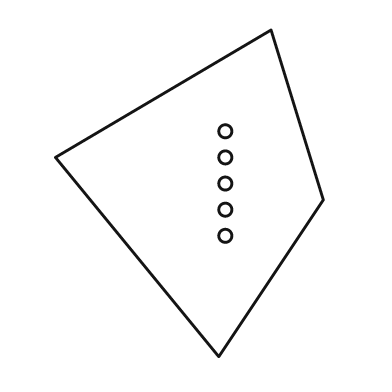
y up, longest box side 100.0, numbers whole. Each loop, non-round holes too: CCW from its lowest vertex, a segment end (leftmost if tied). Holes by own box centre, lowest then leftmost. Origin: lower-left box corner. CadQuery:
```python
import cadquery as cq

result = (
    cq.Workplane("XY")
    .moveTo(50.0, 0.0)
    .lineTo(82.0, 48.0)
    .lineTo(66.0, 100.0)
    .lineTo(0.0, 61.0)
    .close()
    .moveTo(52.0, 37.0)
    .circle(2.0)
    .moveTo(52.0, 45.0)
    .circle(2.0)
    .moveTo(52.0, 53.0)
    .circle(2.0)
    .moveTo(52.0, 61.0)
    .circle(2.0)
    .moveTo(52.0, 69.0)
    .circle(2.0)
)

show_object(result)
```